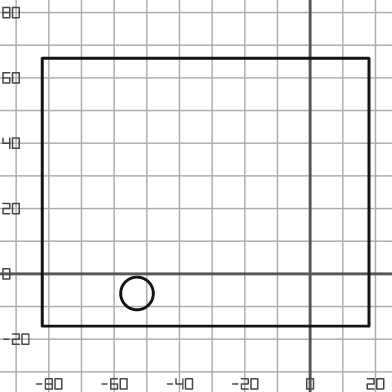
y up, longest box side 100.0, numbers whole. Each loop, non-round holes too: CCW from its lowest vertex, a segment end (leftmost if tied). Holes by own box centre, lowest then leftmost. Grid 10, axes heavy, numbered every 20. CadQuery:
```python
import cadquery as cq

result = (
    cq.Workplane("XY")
    .moveTo(-82.0, -16.0)
    .lineTo(18.0, -16.0)
    .lineTo(18.0, 66.0)
    .lineTo(-82.0, 66.0)
    .close()
    .moveTo(-53.0, -6.0)
    .circle(5.0)
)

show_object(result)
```